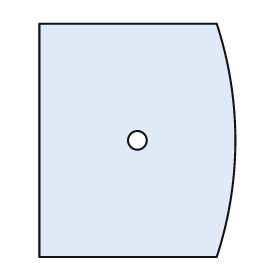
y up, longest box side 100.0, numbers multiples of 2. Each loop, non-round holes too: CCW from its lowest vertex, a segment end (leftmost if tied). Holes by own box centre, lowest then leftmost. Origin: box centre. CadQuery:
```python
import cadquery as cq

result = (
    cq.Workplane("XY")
    .moveTo(-42.0, -50.0)
    .lineTo(34.0, -50.0)
    .threePointArc((42.0, 0.0), (34.0, 50.0))
    .lineTo(-42.0, 50.0)
    .close()
    .moveTo(0.0, 0.0)
    .circle(4.0)
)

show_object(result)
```